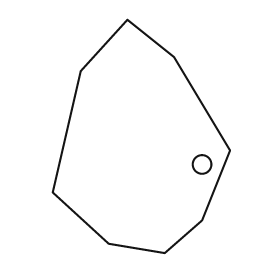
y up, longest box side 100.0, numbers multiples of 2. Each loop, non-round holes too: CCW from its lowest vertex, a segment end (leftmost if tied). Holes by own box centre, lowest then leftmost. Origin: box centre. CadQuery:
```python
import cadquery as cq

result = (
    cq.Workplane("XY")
    .moveTo(10.0, -50.0)
    .lineTo(26.0, -36.0)
    .lineTo(38.0, -6.0)
    .lineTo(14.0, 34.0)
    .lineTo(-6.0, 50.0)
    .lineTo(-26.0, 28.0)
    .lineTo(-38.0, -24.0)
    .lineTo(-14.0, -46.0)
    .close()
    .moveTo(26.0, -12.0)
    .circle(4.0)
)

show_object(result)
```